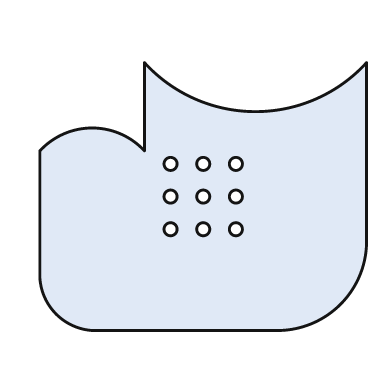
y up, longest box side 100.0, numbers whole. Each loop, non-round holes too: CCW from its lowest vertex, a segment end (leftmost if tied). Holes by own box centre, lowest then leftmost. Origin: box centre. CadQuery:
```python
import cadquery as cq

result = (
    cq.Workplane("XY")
    .moveTo(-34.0, -41.0)
    .lineTo(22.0, -41.0)
    .threePointArc((42.0, -33.0), (50.0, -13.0))
    .lineTo(50.0, 41.0)
    .threePointArc((16.0, 26.0), (-18.0, 41.0))
    .lineTo(-18.0, 14.0)
    .threePointArc((-34.0, 21.0), (-50.0, 14.0))
    .lineTo(-50.0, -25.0)
    .threePointArc((-45.0, -36.0), (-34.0, -41.0))
    .close()
    .moveTo(-10.0, -10.0)
    .circle(2.0)
    .moveTo(0.0, -10.0)
    .circle(2.0)
    .moveTo(10.0, -10.0)
    .circle(2.0)
    .moveTo(-10.0, 0.0)
    .circle(2.0)
    .moveTo(0.0, 0.0)
    .circle(2.0)
    .moveTo(10.0, 0.0)
    .circle(2.0)
    .moveTo(-10.0, 10.0)
    .circle(2.0)
    .moveTo(0.0, 10.0)
    .circle(2.0)
    .moveTo(10.0, 10.0)
    .circle(2.0)
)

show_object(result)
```